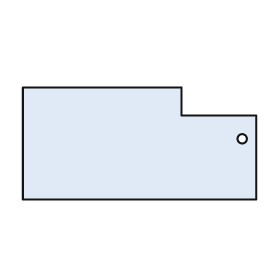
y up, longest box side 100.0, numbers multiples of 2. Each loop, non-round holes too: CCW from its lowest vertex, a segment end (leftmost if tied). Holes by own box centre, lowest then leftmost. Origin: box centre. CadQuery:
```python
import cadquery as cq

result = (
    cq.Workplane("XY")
    .moveTo(-50.0, -24.0)
    .lineTo(50.0, -24.0)
    .lineTo(50.0, 12.0)
    .lineTo(18.0, 12.0)
    .lineTo(18.0, 24.0)
    .lineTo(-50.0, 24.0)
    .close()
    .moveTo(44.0, 2.0)
    .circle(2.0)
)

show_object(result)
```